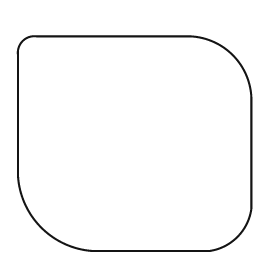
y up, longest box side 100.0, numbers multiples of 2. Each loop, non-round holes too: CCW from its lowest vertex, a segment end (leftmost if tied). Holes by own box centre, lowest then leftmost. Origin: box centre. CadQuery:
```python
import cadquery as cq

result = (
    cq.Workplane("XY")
    .moveTo(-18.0, -46.0)
    .lineTo(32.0, -46.0)
    .threePointArc((44.0, -40.0), (50.0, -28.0))
    .lineTo(50.0, 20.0)
    .threePointArc((42.0, 38.0), (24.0, 46.0))
    .lineTo(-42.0, 46.0)
    .threePointArc((-48.0, 44.0), (-50.0, 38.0))
    .lineTo(-50.0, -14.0)
    .threePointArc((-40.0, -36.0), (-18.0, -46.0))
    .close()
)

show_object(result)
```